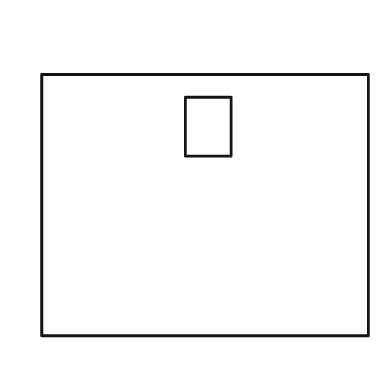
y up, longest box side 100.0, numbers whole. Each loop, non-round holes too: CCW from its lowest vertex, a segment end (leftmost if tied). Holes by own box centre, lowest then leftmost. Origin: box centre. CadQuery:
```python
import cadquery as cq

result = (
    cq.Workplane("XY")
    .moveTo(-50.0, -40.0)
    .lineTo(50.0, -40.0)
    .lineTo(50.0, 40.0)
    .lineTo(-50.0, 40.0)
    .close()
    .moveTo(-6.0, 15.0)
    .lineTo(8.0, 15.0)
    .lineTo(8.0, 33.0)
    .lineTo(-6.0, 33.0)
    .close()
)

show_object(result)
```